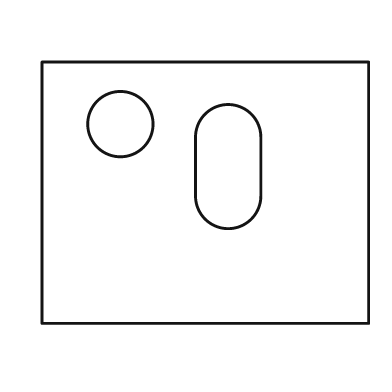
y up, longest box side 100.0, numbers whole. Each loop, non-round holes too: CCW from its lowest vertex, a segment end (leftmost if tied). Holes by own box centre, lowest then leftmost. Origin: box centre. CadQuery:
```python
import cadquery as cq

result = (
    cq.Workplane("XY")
    .moveTo(-50.0, -40.0)
    .lineTo(50.0, -40.0)
    .lineTo(50.0, 40.0)
    .lineTo(-50.0, 40.0)
    .close()
    .moveTo(-3.0, -1.0)
    .threePointArc((7.0, -11.0), (17.0, -1.0))
    .lineTo(17.0, 17.0)
    .threePointArc((7.0, 27.0), (-3.0, 17.0))
    .close()
    .moveTo(-26.0, 21.0)
    .circle(10.0)
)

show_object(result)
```